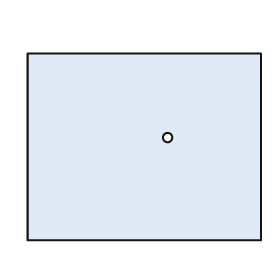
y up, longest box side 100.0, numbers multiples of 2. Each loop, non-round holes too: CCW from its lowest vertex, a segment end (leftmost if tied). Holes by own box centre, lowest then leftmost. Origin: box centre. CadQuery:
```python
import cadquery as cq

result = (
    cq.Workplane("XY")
    .moveTo(-50.0, -40.0)
    .lineTo(50.0, -40.0)
    .lineTo(50.0, 40.0)
    .lineTo(-50.0, 40.0)
    .close()
    .moveTo(10.0, 4.0)
    .circle(2.0)
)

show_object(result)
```